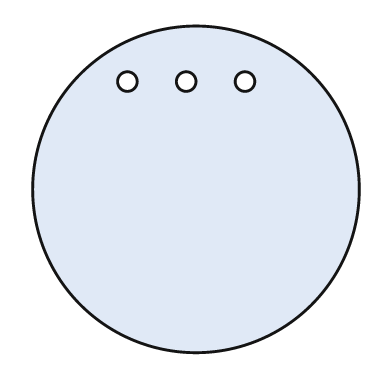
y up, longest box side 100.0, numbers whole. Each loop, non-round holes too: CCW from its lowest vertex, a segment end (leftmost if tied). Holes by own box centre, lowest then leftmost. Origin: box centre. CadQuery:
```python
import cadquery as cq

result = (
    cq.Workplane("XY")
    .moveTo(0.0, 0.0)
    .circle(50.0)
    .moveTo(-21.0, 33.0)
    .circle(3.0)
    .moveTo(-3.0, 33.0)
    .circle(3.0)
    .moveTo(15.0, 33.0)
    .circle(3.0)
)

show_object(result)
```